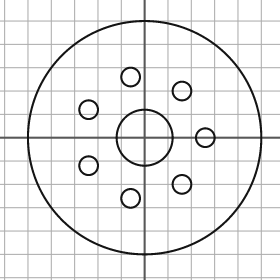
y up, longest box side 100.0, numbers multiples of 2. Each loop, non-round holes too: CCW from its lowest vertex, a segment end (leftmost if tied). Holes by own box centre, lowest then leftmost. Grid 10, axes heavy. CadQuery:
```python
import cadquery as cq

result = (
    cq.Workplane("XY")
    .moveTo(0.0, 0.0)
    .circle(50.0)
    .moveTo(-6.0, -26.0)
    .circle(4.0)
    .moveTo(16.0, -20.0)
    .circle(4.0)
    .moveTo(-24.0, -12.0)
    .circle(4.0)
    .moveTo(0.0, 0.0)
    .circle(12.0)
    .moveTo(26.0, 0.0)
    .circle(4.0)
    .moveTo(-24.0, 12.0)
    .circle(4.0)
    .moveTo(16.0, 20.0)
    .circle(4.0)
    .moveTo(-6.0, 26.0)
    .circle(4.0)
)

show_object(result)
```